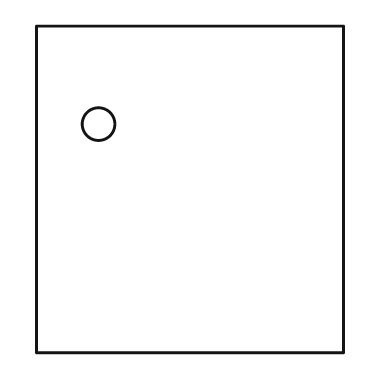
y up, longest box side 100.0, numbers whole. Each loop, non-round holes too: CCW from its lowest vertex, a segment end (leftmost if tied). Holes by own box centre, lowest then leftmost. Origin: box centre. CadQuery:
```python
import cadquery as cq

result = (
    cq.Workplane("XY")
    .moveTo(-47.0, -50.0)
    .lineTo(47.0, -50.0)
    .lineTo(47.0, 50.0)
    .lineTo(-47.0, 50.0)
    .close()
    .moveTo(-28.0, 20.0)
    .circle(5.0)
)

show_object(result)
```